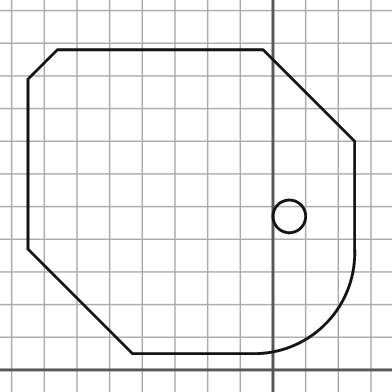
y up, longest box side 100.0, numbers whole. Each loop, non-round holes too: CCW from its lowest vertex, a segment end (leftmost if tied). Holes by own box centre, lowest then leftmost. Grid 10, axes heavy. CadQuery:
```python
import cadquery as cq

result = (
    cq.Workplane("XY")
    .moveTo(-43.0, 5.0)
    .lineTo(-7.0, 5.0)
    .threePointArc((16.0, 14.0), (25.0, 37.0))
    .lineTo(25.0, 70.0)
    .lineTo(-3.0, 98.0)
    .lineTo(-66.0, 98.0)
    .lineTo(-75.0, 89.0)
    .lineTo(-75.0, 37.0)
    .close()
    .moveTo(5.0, 47.0)
    .circle(5.0)
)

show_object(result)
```